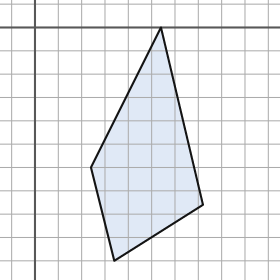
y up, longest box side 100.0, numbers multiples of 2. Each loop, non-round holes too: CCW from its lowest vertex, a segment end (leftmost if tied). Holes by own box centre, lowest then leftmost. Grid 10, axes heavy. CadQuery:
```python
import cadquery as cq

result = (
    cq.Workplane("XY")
    .moveTo(34.0, -100.0)
    .lineTo(72.0, -76.0)
    .lineTo(54.0, 0.0)
    .lineTo(24.0, -60.0)
    .close()
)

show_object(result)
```